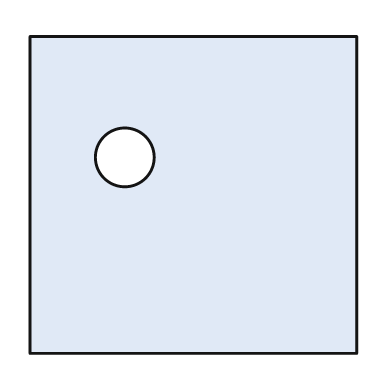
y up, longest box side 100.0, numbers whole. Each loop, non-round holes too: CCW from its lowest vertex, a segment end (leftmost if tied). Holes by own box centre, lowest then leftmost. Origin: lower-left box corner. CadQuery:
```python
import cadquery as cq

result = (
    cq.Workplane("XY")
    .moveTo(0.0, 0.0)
    .lineTo(100.0, 0.0)
    .lineTo(100.0, 97.0)
    .lineTo(0.0, 97.0)
    .close()
    .moveTo(29.0, 60.0)
    .circle(9.0)
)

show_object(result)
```